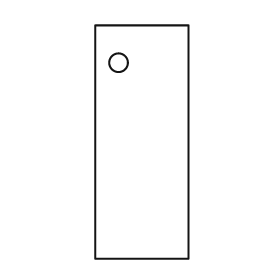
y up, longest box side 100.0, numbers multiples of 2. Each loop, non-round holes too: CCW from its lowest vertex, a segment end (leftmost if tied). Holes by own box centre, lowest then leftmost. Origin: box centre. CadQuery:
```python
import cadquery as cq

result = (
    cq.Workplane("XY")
    .moveTo(-20.0, -50.0)
    .lineTo(20.0, -50.0)
    .lineTo(20.0, 50.0)
    .lineTo(-20.0, 50.0)
    .close()
    .moveTo(-10.0, 34.0)
    .circle(4.0)
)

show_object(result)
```